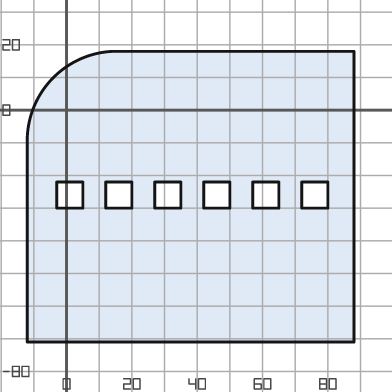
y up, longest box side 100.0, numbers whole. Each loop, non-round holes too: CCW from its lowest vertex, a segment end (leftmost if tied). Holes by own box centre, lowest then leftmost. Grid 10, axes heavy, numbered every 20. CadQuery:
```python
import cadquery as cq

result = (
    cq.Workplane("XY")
    .moveTo(-12.0, -71.0)
    .lineTo(88.0, -71.0)
    .lineTo(88.0, 18.0)
    .lineTo(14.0, 18.0)
    .threePointArc((-4.0, 10.0), (-12.0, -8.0))
    .close()
    .moveTo(-3.0, -30.0)
    .lineTo(5.0, -30.0)
    .lineTo(5.0, -22.0)
    .lineTo(-3.0, -22.0)
    .close()
    .moveTo(12.0, -30.0)
    .lineTo(20.0, -30.0)
    .lineTo(20.0, -22.0)
    .lineTo(12.0, -22.0)
    .close()
    .moveTo(27.0, -30.0)
    .lineTo(35.0, -30.0)
    .lineTo(35.0, -22.0)
    .lineTo(27.0, -22.0)
    .close()
    .moveTo(42.0, -30.0)
    .lineTo(50.0, -30.0)
    .lineTo(50.0, -22.0)
    .lineTo(42.0, -22.0)
    .close()
    .moveTo(57.0, -30.0)
    .lineTo(65.0, -30.0)
    .lineTo(65.0, -22.0)
    .lineTo(57.0, -22.0)
    .close()
    .moveTo(72.0, -30.0)
    .lineTo(80.0, -30.0)
    .lineTo(80.0, -22.0)
    .lineTo(72.0, -22.0)
    .close()
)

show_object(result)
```